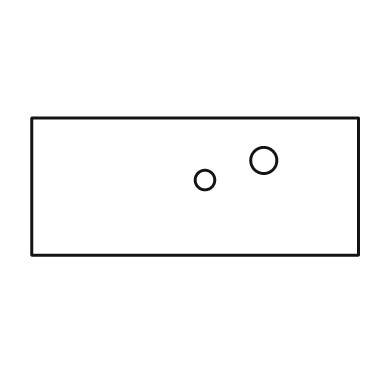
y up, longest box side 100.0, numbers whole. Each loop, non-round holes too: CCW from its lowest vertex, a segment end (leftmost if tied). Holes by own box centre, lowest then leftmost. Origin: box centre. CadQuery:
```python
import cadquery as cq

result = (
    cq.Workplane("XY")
    .moveTo(-50.0, -21.0)
    .lineTo(50.0, -21.0)
    .lineTo(50.0, 21.0)
    .lineTo(-50.0, 21.0)
    .close()
    .moveTo(3.0, 2.0)
    .circle(3.0)
    .moveTo(21.0, 8.0)
    .circle(4.0)
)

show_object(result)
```